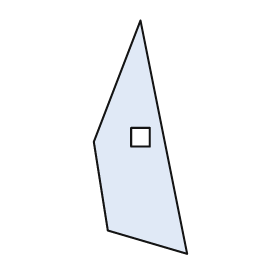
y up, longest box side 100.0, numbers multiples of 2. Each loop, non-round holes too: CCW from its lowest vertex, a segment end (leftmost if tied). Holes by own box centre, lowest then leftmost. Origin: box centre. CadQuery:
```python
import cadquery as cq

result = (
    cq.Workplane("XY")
    .moveTo(20.0, -50.0)
    .lineTo(0.0, 50.0)
    .lineTo(-20.0, -2.0)
    .lineTo(-14.0, -40.0)
    .close()
    .moveTo(-4.0, -4.0)
    .lineTo(4.0, -4.0)
    .lineTo(4.0, 4.0)
    .lineTo(-4.0, 4.0)
    .close()
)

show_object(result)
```